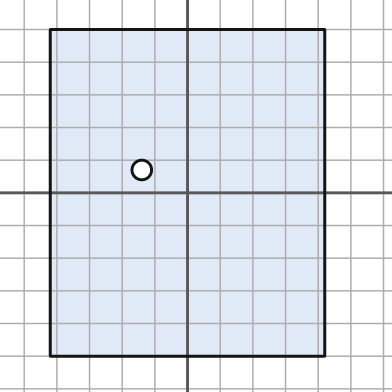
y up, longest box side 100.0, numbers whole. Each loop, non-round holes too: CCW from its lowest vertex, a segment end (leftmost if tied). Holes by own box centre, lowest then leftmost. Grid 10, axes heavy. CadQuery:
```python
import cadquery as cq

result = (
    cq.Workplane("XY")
    .moveTo(-42.0, -50.0)
    .lineTo(42.0, -50.0)
    .lineTo(42.0, 50.0)
    .lineTo(-42.0, 50.0)
    .close()
    .moveTo(-14.0, 7.0)
    .circle(3.0)
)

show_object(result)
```